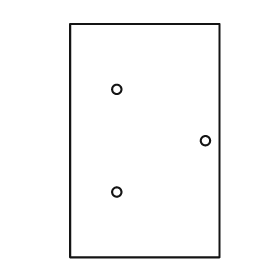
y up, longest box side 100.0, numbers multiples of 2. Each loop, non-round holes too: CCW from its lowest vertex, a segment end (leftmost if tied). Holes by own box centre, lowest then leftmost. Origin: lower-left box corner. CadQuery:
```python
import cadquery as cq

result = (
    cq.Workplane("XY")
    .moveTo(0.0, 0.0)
    .lineTo(64.0, 0.0)
    .lineTo(64.0, 100.0)
    .lineTo(0.0, 100.0)
    .close()
    .moveTo(20.0, 28.0)
    .circle(2.0)
    .moveTo(58.0, 50.0)
    .circle(2.0)
    .moveTo(20.0, 72.0)
    .circle(2.0)
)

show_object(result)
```